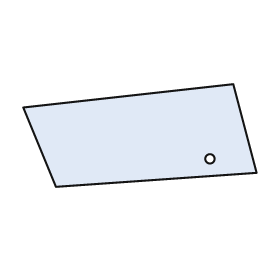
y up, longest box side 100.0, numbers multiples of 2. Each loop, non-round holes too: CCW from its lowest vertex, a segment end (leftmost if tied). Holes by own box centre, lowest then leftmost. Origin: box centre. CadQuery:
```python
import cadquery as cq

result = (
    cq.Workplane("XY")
    .moveTo(-36.0, -22.0)
    .lineTo(50.0, -16.0)
    .lineTo(40.0, 22.0)
    .lineTo(-50.0, 12.0)
    .close()
    .moveTo(30.0, -10.0)
    .circle(2.0)
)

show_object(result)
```